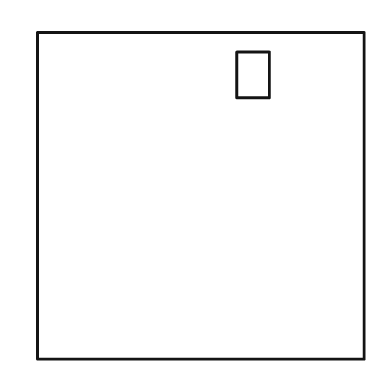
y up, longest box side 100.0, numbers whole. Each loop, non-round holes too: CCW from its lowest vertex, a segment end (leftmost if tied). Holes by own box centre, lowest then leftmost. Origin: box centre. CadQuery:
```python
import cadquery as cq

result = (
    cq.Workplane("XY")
    .moveTo(-50.0, -50.0)
    .lineTo(50.0, -50.0)
    .lineTo(50.0, 50.0)
    .lineTo(-50.0, 50.0)
    .close()
    .moveTo(11.0, 30.0)
    .lineTo(21.0, 30.0)
    .lineTo(21.0, 44.0)
    .lineTo(11.0, 44.0)
    .close()
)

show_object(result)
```